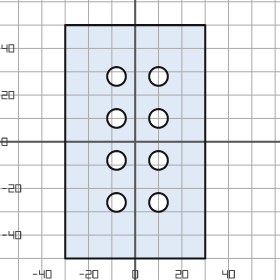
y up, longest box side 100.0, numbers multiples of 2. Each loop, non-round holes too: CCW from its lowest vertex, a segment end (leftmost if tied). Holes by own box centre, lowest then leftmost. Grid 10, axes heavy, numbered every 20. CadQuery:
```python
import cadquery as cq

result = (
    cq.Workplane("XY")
    .moveTo(-30.0, -50.0)
    .lineTo(30.0, -50.0)
    .lineTo(30.0, 50.0)
    .lineTo(-30.0, 50.0)
    .close()
    .moveTo(-8.0, -26.0)
    .circle(4.0)
    .moveTo(10.0, -26.0)
    .circle(4.0)
    .moveTo(-8.0, -8.0)
    .circle(4.0)
    .moveTo(10.0, -8.0)
    .circle(4.0)
    .moveTo(-8.0, 10.0)
    .circle(4.0)
    .moveTo(10.0, 10.0)
    .circle(4.0)
    .moveTo(-8.0, 28.0)
    .circle(4.0)
    .moveTo(10.0, 28.0)
    .circle(4.0)
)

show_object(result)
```